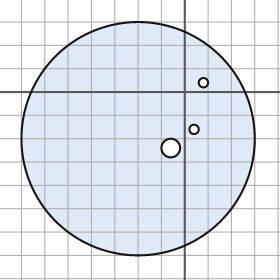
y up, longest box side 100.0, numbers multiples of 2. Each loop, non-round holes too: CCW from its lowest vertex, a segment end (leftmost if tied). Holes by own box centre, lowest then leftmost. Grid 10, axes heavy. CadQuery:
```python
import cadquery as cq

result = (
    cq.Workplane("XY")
    .moveTo(-20.0, -20.0)
    .circle(50.0)
    .moveTo(-6.0, -24.0)
    .circle(4.0)
    .moveTo(4.0, -16.0)
    .circle(2.0)
    .moveTo(8.0, 4.0)
    .circle(2.0)
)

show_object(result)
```